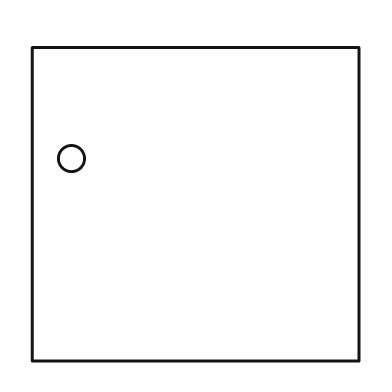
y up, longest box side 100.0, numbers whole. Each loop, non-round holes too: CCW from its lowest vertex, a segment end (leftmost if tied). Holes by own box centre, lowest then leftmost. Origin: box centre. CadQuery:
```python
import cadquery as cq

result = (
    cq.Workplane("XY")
    .moveTo(-50.0, -48.0)
    .lineTo(50.0, -48.0)
    .lineTo(50.0, 48.0)
    .lineTo(-50.0, 48.0)
    .close()
    .moveTo(-38.0, 14.0)
    .circle(4.0)
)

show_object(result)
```